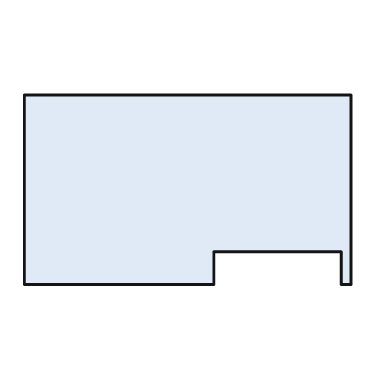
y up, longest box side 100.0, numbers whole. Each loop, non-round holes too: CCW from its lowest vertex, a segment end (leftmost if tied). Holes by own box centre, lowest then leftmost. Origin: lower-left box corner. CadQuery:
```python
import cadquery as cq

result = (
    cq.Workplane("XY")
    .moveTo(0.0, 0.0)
    .lineTo(58.0, 0.0)
    .lineTo(58.0, 10.0)
    .lineTo(97.0, 10.0)
    .lineTo(97.0, 0.0)
    .lineTo(100.0, 0.0)
    .lineTo(100.0, 58.0)
    .lineTo(0.0, 58.0)
    .close()
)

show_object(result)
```